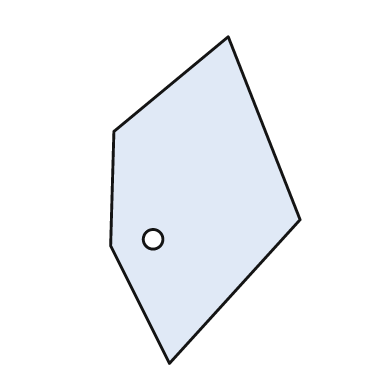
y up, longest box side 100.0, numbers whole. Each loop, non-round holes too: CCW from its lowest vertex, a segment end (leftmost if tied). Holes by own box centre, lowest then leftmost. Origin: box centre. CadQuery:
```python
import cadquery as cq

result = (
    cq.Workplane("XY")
    .moveTo(-11.0, -50.0)
    .lineTo(29.0, -6.0)
    .lineTo(7.0, 50.0)
    .lineTo(-28.0, 21.0)
    .lineTo(-29.0, -14.0)
    .close()
    .moveTo(-16.0, -12.0)
    .circle(3.0)
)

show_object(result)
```